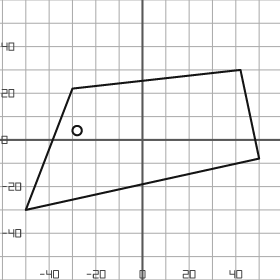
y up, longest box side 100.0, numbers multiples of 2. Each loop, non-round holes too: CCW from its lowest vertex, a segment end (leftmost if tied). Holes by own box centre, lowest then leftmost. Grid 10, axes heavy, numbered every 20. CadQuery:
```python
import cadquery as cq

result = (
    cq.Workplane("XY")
    .moveTo(-50.0, -30.0)
    .lineTo(50.0, -8.0)
    .lineTo(42.0, 30.0)
    .lineTo(-30.0, 22.0)
    .close()
    .moveTo(-28.0, 4.0)
    .circle(2.0)
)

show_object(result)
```